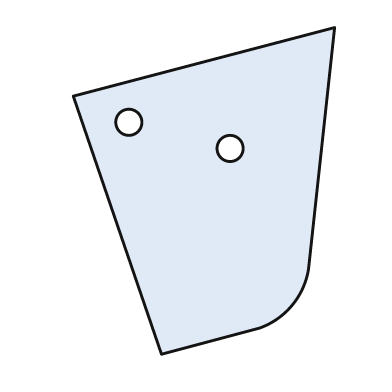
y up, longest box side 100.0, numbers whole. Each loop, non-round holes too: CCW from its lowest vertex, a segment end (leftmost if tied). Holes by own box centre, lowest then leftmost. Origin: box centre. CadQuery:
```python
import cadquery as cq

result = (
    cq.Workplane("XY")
    .moveTo(-13.0, -50.0)
    .lineTo(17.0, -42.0)
    .threePointArc((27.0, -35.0), (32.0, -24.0))
    .lineTo(40.0, 50.0)
    .lineTo(-40.0, 29.0)
    .close()
    .moveTo(8.0, 13.0)
    .circle(4.0)
    .moveTo(-23.0, 21.0)
    .circle(4.0)
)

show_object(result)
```